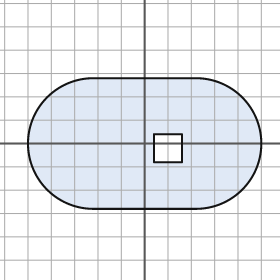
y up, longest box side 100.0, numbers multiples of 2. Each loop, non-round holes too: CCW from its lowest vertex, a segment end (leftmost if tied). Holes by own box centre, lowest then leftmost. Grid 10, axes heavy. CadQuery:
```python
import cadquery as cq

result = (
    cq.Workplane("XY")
    .moveTo(-22.0, -28.0)
    .lineTo(22.0, -28.0)
    .threePointArc((50.0, 0.0), (22.0, 28.0))
    .lineTo(-22.0, 28.0)
    .threePointArc((-50.0, 0.0), (-22.0, -28.0))
    .close()
    .moveTo(4.0, -8.0)
    .lineTo(16.0, -8.0)
    .lineTo(16.0, 4.0)
    .lineTo(4.0, 4.0)
    .close()
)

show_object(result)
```